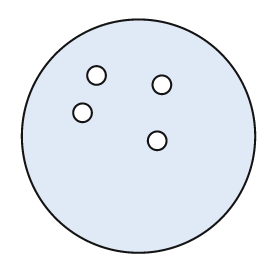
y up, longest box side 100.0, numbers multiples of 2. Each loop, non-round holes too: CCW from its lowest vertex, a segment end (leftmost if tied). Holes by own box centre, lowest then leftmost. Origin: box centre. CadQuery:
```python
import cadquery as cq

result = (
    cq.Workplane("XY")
    .moveTo(0.0, 0.0)
    .circle(50.0)
    .moveTo(8.0, -2.0)
    .circle(4.0)
    .moveTo(-24.0, 10.0)
    .circle(4.0)
    .moveTo(10.0, 22.0)
    .circle(4.0)
    .moveTo(-18.0, 26.0)
    .circle(4.0)
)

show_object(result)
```